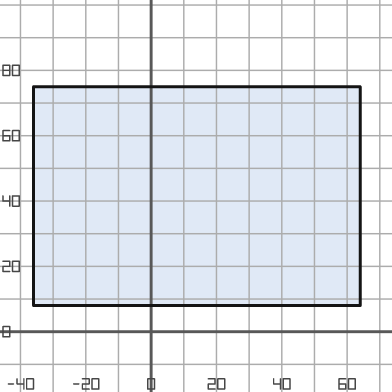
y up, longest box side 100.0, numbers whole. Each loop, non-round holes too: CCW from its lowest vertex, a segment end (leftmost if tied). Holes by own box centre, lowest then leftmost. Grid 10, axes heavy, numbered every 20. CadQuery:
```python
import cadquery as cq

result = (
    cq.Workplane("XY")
    .moveTo(-36.0, 8.0)
    .lineTo(64.0, 8.0)
    .lineTo(64.0, 75.0)
    .lineTo(-36.0, 75.0)
    .close()
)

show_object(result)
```